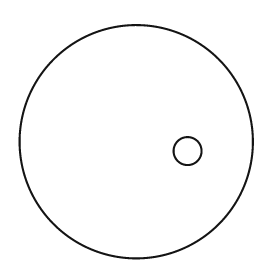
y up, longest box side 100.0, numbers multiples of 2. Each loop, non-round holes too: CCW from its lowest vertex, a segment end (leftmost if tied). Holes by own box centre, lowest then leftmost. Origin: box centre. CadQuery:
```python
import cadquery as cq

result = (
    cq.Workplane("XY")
    .moveTo(0.0, 0.0)
    .circle(50.0)
    .moveTo(22.0, -4.0)
    .circle(6.0)
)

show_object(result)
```